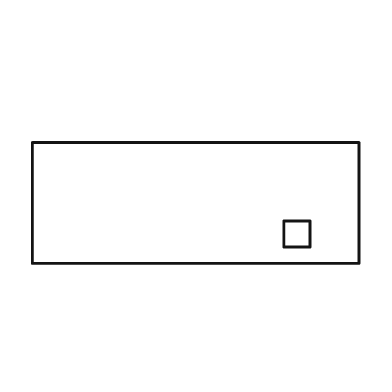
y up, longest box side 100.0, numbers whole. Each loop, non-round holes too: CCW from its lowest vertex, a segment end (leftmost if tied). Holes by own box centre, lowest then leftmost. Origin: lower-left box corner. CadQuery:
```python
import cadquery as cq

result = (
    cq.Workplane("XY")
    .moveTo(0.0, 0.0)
    .lineTo(100.0, 0.0)
    .lineTo(100.0, 37.0)
    .lineTo(0.0, 37.0)
    .close()
    .moveTo(77.0, 5.0)
    .lineTo(85.0, 5.0)
    .lineTo(85.0, 13.0)
    .lineTo(77.0, 13.0)
    .close()
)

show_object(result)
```